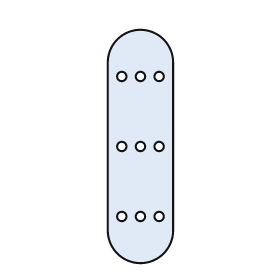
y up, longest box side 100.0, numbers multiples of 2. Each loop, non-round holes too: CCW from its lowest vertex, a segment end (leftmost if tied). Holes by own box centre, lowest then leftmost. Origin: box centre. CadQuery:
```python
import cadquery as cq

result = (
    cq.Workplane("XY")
    .moveTo(-14.0, -36.0)
    .threePointArc((0.0, -50.0), (14.0, -36.0))
    .lineTo(14.0, 36.0)
    .threePointArc((0.0, 50.0), (-14.0, 36.0))
    .close()
    .moveTo(-8.0, -30.0)
    .circle(2.0)
    .moveTo(0.0, -30.0)
    .circle(2.0)
    .moveTo(8.0, -30.0)
    .circle(2.0)
    .moveTo(-8.0, 0.0)
    .circle(2.0)
    .moveTo(0.0, 0.0)
    .circle(2.0)
    .moveTo(8.0, 0.0)
    .circle(2.0)
    .moveTo(-8.0, 30.0)
    .circle(2.0)
    .moveTo(0.0, 30.0)
    .circle(2.0)
    .moveTo(8.0, 30.0)
    .circle(2.0)
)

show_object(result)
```